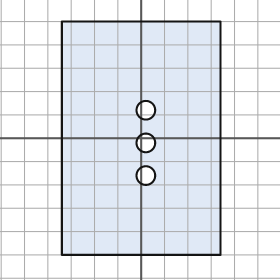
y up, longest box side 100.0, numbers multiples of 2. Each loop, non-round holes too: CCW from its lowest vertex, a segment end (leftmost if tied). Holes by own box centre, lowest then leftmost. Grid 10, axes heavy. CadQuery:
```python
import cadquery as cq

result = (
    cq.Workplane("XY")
    .moveTo(-34.0, -50.0)
    .lineTo(34.0, -50.0)
    .lineTo(34.0, 50.0)
    .lineTo(-34.0, 50.0)
    .close()
    .moveTo(2.0, -16.0)
    .circle(4.0)
    .moveTo(2.0, -2.0)
    .circle(4.0)
    .moveTo(2.0, 12.0)
    .circle(4.0)
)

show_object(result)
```